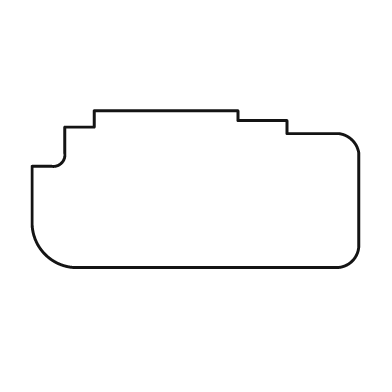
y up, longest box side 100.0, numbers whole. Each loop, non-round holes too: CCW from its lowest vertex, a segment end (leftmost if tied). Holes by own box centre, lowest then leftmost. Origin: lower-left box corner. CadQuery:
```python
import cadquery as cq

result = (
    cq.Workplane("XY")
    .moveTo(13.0, 0.0)
    .lineTo(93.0, 0.0)
    .threePointArc((98.0, 2.0), (100.0, 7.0))
    .lineTo(100.0, 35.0)
    .threePointArc((98.0, 39.0), (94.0, 41.0))
    .lineTo(78.0, 41.0)
    .lineTo(78.0, 45.0)
    .lineTo(63.0, 45.0)
    .lineTo(63.0, 48.0)
    .lineTo(19.0, 48.0)
    .lineTo(19.0, 43.0)
    .lineTo(10.0, 43.0)
    .lineTo(10.0, 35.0)
    .threePointArc((9.0, 32.0), (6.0, 31.0))
    .lineTo(0.0, 31.0)
    .lineTo(0.0, 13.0)
    .threePointArc((4.0, 4.0), (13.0, 0.0))
    .close()
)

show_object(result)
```